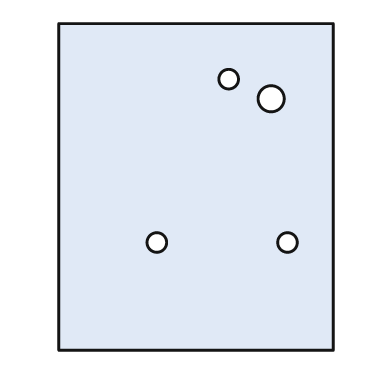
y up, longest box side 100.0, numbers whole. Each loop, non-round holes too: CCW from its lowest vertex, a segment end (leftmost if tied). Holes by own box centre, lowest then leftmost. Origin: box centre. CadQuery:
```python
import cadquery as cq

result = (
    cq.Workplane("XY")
    .moveTo(-42.0, -50.0)
    .lineTo(42.0, -50.0)
    .lineTo(42.0, 50.0)
    .lineTo(-42.0, 50.0)
    .close()
    .moveTo(-12.0, -17.0)
    .circle(3.0)
    .moveTo(28.0, -17.0)
    .circle(3.0)
    .moveTo(23.0, 27.0)
    .circle(4.0)
    .moveTo(10.0, 33.0)
    .circle(3.0)
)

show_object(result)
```